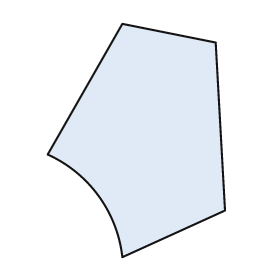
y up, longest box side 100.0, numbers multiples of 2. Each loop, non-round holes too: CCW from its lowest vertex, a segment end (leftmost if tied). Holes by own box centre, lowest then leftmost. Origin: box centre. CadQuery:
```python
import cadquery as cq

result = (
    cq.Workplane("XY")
    .moveTo(-6.0, -50.0)
    .lineTo(38.0, -30.0)
    .lineTo(34.0, 42.0)
    .lineTo(-6.0, 50.0)
    .lineTo(-38.0, -6.0)
    .threePointArc((-16.0, -24.0), (-6.0, -50.0))
    .close()
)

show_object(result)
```